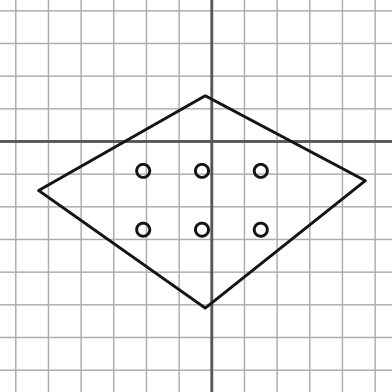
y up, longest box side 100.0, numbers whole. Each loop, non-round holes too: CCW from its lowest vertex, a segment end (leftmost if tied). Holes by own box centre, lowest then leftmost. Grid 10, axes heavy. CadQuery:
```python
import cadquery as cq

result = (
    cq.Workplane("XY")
    .moveTo(-2.0, -51.0)
    .lineTo(47.0, -12.0)
    .lineTo(-2.0, 14.0)
    .lineTo(-53.0, -15.0)
    .close()
    .moveTo(-21.0, -27.0)
    .circle(2.0)
    .moveTo(-3.0, -27.0)
    .circle(2.0)
    .moveTo(15.0, -27.0)
    .circle(2.0)
    .moveTo(-21.0, -9.0)
    .circle(2.0)
    .moveTo(-3.0, -9.0)
    .circle(2.0)
    .moveTo(15.0, -9.0)
    .circle(2.0)
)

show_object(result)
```